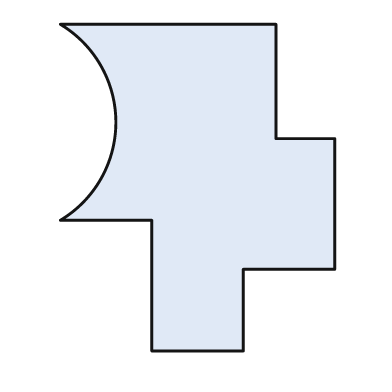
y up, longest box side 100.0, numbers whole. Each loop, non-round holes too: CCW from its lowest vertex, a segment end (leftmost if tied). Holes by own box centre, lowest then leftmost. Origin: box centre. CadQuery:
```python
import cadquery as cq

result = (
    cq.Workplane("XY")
    .moveTo(-14.0, -50.0)
    .lineTo(14.0, -50.0)
    .lineTo(14.0, -25.0)
    .lineTo(42.0, -25.0)
    .lineTo(42.0, 15.0)
    .lineTo(24.0, 15.0)
    .lineTo(24.0, 50.0)
    .lineTo(-42.0, 50.0)
    .threePointArc((-25.0, 20.0), (-42.0, -10.0))
    .lineTo(-14.0, -10.0)
    .close()
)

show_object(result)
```